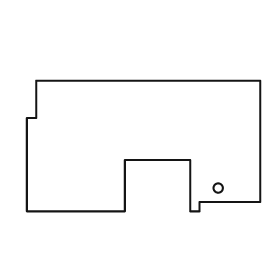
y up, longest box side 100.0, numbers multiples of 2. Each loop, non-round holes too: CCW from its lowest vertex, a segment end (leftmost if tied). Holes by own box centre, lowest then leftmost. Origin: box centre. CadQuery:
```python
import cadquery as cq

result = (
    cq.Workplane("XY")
    .moveTo(-50.0, -28.0)
    .lineTo(-8.0, -28.0)
    .lineTo(-8.0, -6.0)
    .lineTo(20.0, -6.0)
    .lineTo(20.0, -28.0)
    .lineTo(24.0, -28.0)
    .lineTo(24.0, -24.0)
    .lineTo(50.0, -24.0)
    .lineTo(50.0, 28.0)
    .lineTo(-46.0, 28.0)
    .lineTo(-46.0, 12.0)
    .lineTo(-50.0, 12.0)
    .close()
    .moveTo(32.0, -18.0)
    .circle(2.0)
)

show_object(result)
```